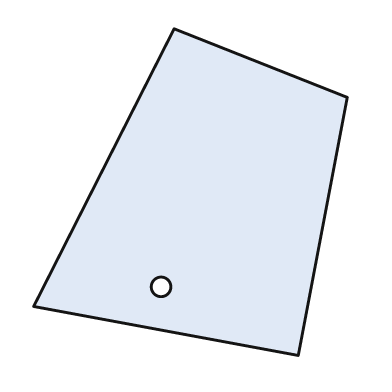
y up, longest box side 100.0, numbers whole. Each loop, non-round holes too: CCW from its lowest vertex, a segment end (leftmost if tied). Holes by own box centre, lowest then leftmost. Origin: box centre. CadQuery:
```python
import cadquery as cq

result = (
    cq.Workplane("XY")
    .moveTo(33.0, -50.0)
    .lineTo(48.0, 29.0)
    .lineTo(-5.0, 50.0)
    .lineTo(-48.0, -35.0)
    .close()
    .moveTo(-9.0, -29.0)
    .circle(3.0)
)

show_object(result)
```